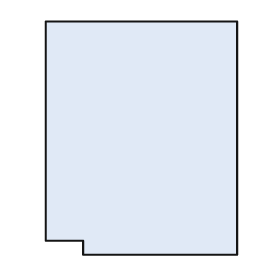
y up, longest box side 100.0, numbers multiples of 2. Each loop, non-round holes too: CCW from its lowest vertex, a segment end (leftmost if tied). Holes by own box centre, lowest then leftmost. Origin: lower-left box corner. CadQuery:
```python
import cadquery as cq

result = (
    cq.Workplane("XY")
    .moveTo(16.0, 0.0)
    .lineTo(82.0, 0.0)
    .lineTo(82.0, 100.0)
    .lineTo(0.0, 100.0)
    .lineTo(0.0, 6.0)
    .lineTo(16.0, 6.0)
    .close()
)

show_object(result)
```